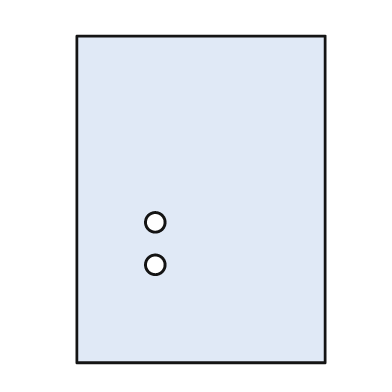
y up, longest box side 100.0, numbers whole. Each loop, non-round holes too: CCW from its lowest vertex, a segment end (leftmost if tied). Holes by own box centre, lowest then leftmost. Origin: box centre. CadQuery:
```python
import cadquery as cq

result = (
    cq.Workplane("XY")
    .moveTo(-38.0, -50.0)
    .lineTo(38.0, -50.0)
    .lineTo(38.0, 50.0)
    .lineTo(-38.0, 50.0)
    .close()
    .moveTo(-14.0, -20.0)
    .circle(3.0)
    .moveTo(-14.0, -7.0)
    .circle(3.0)
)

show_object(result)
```